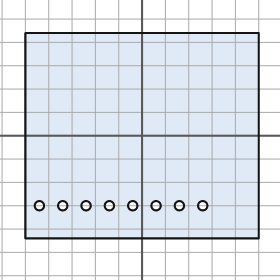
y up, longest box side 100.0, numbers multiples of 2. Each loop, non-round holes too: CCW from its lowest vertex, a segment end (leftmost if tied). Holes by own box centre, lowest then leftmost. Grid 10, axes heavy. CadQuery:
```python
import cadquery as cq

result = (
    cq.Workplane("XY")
    .moveTo(-50.0, -44.0)
    .lineTo(50.0, -44.0)
    .lineTo(50.0, 44.0)
    .lineTo(-50.0, 44.0)
    .close()
    .moveTo(-44.0, -30.0)
    .circle(2.0)
    .moveTo(-34.0, -30.0)
    .circle(2.0)
    .moveTo(-24.0, -30.0)
    .circle(2.0)
    .moveTo(-14.0, -30.0)
    .circle(2.0)
    .moveTo(-4.0, -30.0)
    .circle(2.0)
    .moveTo(6.0, -30.0)
    .circle(2.0)
    .moveTo(16.0, -30.0)
    .circle(2.0)
    .moveTo(26.0, -30.0)
    .circle(2.0)
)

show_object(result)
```